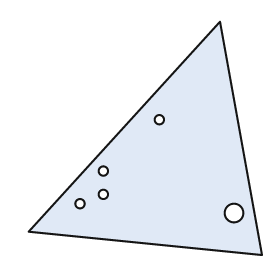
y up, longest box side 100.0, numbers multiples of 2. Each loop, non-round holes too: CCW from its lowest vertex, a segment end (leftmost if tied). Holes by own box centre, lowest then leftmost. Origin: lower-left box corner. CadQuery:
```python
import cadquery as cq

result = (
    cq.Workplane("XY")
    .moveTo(100.0, 0.0)
    .lineTo(82.0, 100.0)
    .lineTo(0.0, 10.0)
    .close()
    .moveTo(88.0, 18.0)
    .circle(4.0)
    .moveTo(22.0, 22.0)
    .circle(2.0)
    .moveTo(32.0, 26.0)
    .circle(2.0)
    .moveTo(32.0, 36.0)
    .circle(2.0)
    .moveTo(56.0, 58.0)
    .circle(2.0)
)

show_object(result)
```